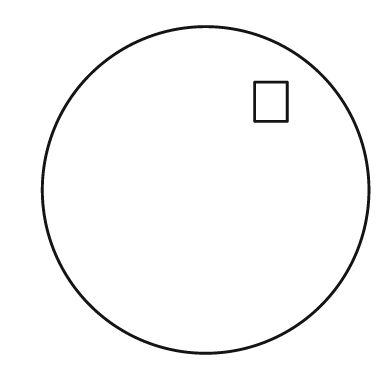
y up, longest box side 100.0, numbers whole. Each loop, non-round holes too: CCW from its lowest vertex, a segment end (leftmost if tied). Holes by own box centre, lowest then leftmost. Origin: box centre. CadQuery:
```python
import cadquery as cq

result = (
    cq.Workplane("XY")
    .moveTo(0.0, 0.0)
    .circle(50.0)
    .moveTo(15.0, 21.0)
    .lineTo(25.0, 21.0)
    .lineTo(25.0, 33.0)
    .lineTo(15.0, 33.0)
    .close()
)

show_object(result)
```